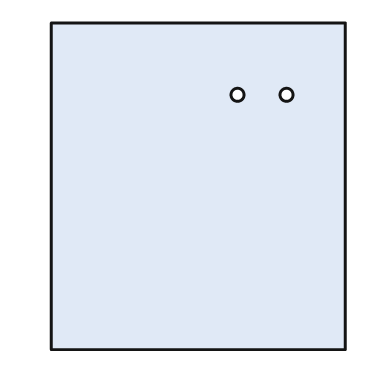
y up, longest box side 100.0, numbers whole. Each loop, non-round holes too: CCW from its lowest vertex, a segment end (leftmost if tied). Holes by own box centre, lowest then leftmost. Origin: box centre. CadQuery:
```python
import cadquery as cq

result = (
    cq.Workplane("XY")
    .moveTo(-45.0, -50.0)
    .lineTo(45.0, -50.0)
    .lineTo(45.0, 50.0)
    .lineTo(-45.0, 50.0)
    .close()
    .moveTo(12.0, 28.0)
    .circle(2.0)
    .moveTo(27.0, 28.0)
    .circle(2.0)
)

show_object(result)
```